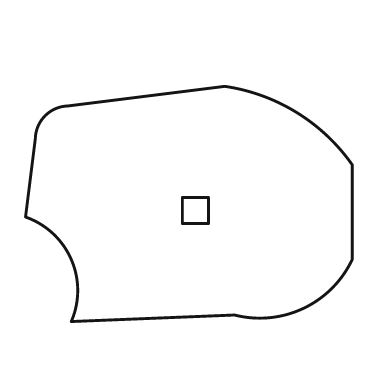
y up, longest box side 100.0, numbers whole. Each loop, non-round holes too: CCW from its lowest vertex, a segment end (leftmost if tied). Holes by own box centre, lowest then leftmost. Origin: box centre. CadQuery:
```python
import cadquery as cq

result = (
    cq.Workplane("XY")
    .moveTo(-36.0, -36.0)
    .lineTo(14.0, -34.0)
    .threePointArc((35.0, -32.0), (50.0, -17.0))
    .lineTo(50.0, 12.0)
    .threePointArc((33.0, 28.0), (11.0, 36.0))
    .lineTo(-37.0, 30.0)
    .threePointArc((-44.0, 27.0), (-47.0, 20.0))
    .lineTo(-50.0, -4.0)
    .threePointArc((-36.0, -17.0), (-36.0, -36.0))
    .close()
    .moveTo(-2.0, -6.0)
    .lineTo(6.0, -6.0)
    .lineTo(6.0, 2.0)
    .lineTo(-2.0, 2.0)
    .close()
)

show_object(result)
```